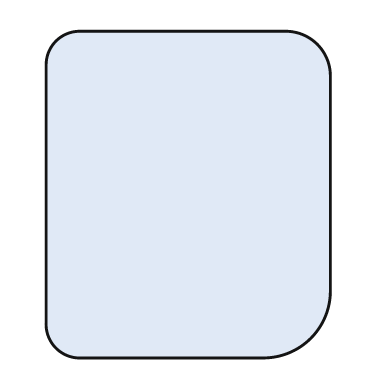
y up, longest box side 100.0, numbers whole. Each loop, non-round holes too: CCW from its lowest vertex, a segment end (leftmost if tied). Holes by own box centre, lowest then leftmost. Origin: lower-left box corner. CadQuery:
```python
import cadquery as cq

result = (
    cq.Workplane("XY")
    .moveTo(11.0, 0.0)
    .lineTo(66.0, 0.0)
    .threePointArc((81.0, 6.0), (87.0, 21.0))
    .lineTo(87.0, 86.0)
    .threePointArc((83.0, 96.0), (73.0, 100.0))
    .lineTo(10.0, 100.0)
    .threePointArc((3.0, 97.0), (0.0, 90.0))
    .lineTo(0.0, 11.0)
    .threePointArc((3.0, 3.0), (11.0, 0.0))
    .close()
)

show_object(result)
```